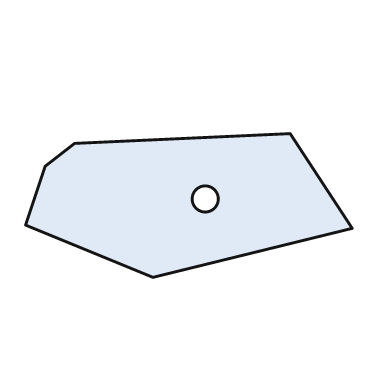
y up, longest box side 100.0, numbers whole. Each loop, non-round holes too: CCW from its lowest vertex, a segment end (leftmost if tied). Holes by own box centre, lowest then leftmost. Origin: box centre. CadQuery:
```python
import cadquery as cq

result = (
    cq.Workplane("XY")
    .moveTo(-11.0, -22.0)
    .lineTo(50.0, -7.0)
    .lineTo(31.0, 22.0)
    .lineTo(-35.0, 19.0)
    .lineTo(-44.0, 12.0)
    .lineTo(-50.0, -6.0)
    .close()
    .moveTo(5.0, 2.0)
    .circle(4.0)
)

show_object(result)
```